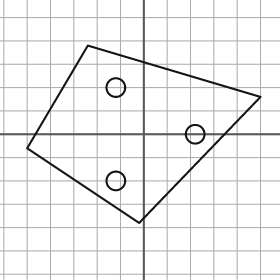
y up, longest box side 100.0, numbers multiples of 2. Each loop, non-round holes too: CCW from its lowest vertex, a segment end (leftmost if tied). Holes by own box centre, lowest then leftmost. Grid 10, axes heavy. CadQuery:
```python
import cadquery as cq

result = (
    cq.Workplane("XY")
    .moveTo(-2.0, -38.0)
    .lineTo(50.0, 16.0)
    .lineTo(-24.0, 38.0)
    .lineTo(-50.0, -6.0)
    .close()
    .moveTo(-12.0, -20.0)
    .circle(4.0)
    .moveTo(22.0, 0.0)
    .circle(4.0)
    .moveTo(-12.0, 20.0)
    .circle(4.0)
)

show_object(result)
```